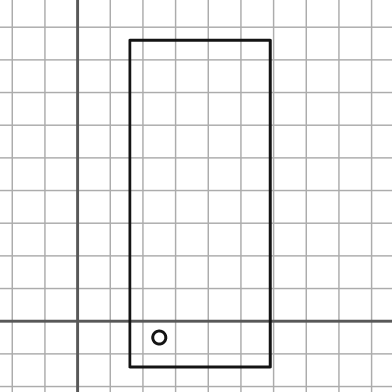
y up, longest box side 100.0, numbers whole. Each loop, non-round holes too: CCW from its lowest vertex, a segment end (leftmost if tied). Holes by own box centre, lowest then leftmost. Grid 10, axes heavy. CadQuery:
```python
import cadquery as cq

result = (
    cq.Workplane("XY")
    .moveTo(16.0, -14.0)
    .lineTo(59.0, -14.0)
    .lineTo(59.0, 86.0)
    .lineTo(16.0, 86.0)
    .close()
    .moveTo(25.0, -5.0)
    .circle(2.0)
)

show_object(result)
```